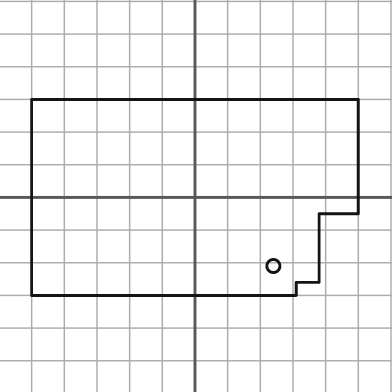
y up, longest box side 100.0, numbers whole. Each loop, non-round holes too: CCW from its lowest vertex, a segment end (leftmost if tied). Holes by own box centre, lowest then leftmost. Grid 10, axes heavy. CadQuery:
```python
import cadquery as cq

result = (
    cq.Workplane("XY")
    .moveTo(-50.0, -30.0)
    .lineTo(31.0, -30.0)
    .lineTo(31.0, -26.0)
    .lineTo(38.0, -26.0)
    .lineTo(38.0, -5.0)
    .lineTo(50.0, -5.0)
    .lineTo(50.0, 30.0)
    .lineTo(-50.0, 30.0)
    .close()
    .moveTo(24.0, -21.0)
    .circle(2.0)
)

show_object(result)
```